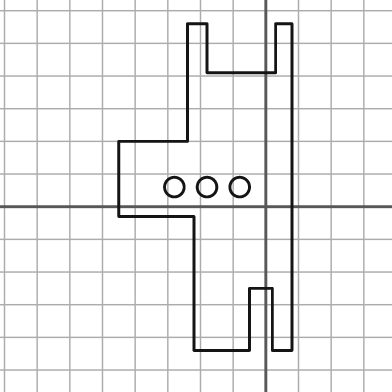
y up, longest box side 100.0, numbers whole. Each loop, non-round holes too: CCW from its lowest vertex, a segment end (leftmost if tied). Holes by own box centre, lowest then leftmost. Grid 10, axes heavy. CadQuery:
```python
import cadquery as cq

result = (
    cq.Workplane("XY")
    .moveTo(-22.0, -44.0)
    .lineTo(-5.0, -44.0)
    .lineTo(-5.0, -25.0)
    .lineTo(2.0, -25.0)
    .lineTo(2.0, -44.0)
    .lineTo(8.0, -44.0)
    .lineTo(8.0, 56.0)
    .lineTo(3.0, 56.0)
    .lineTo(3.0, 41.0)
    .lineTo(-18.0, 41.0)
    .lineTo(-18.0, 56.0)
    .lineTo(-24.0, 56.0)
    .lineTo(-24.0, 20.0)
    .lineTo(-45.0, 20.0)
    .lineTo(-45.0, -3.0)
    .lineTo(-22.0, -3.0)
    .close()
    .moveTo(-28.0, 6.0)
    .circle(3.0)
    .moveTo(-18.0, 6.0)
    .circle(3.0)
    .moveTo(-8.0, 6.0)
    .circle(3.0)
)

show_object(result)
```